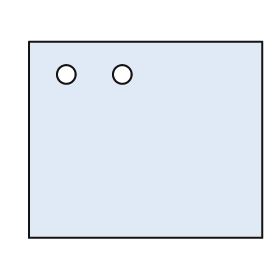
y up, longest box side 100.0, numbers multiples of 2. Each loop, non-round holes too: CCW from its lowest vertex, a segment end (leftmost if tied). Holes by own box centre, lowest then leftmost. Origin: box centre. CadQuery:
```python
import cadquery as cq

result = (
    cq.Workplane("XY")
    .moveTo(-50.0, -42.0)
    .lineTo(50.0, -42.0)
    .lineTo(50.0, 42.0)
    .lineTo(-50.0, 42.0)
    .close()
    .moveTo(-34.0, 28.0)
    .circle(4.0)
    .moveTo(-10.0, 28.0)
    .circle(4.0)
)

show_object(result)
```